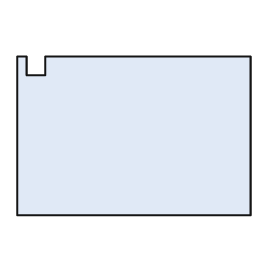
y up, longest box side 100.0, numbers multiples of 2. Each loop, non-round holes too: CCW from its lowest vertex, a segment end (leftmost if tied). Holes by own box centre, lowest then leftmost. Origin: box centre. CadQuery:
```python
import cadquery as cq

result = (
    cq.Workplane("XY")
    .moveTo(-50.0, -34.0)
    .lineTo(50.0, -34.0)
    .lineTo(50.0, 34.0)
    .lineTo(-38.0, 34.0)
    .lineTo(-38.0, 26.0)
    .lineTo(-46.0, 26.0)
    .lineTo(-46.0, 34.0)
    .lineTo(-50.0, 34.0)
    .close()
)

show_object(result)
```